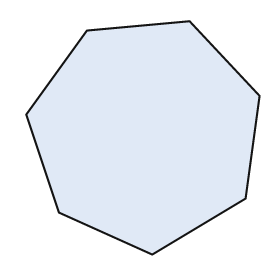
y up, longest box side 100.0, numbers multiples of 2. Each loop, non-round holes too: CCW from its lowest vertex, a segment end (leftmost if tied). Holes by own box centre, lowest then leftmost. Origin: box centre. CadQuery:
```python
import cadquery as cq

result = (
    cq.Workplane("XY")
    .moveTo(4.0, -50.0)
    .lineTo(44.0, -26.0)
    .lineTo(50.0, 18.0)
    .lineTo(20.0, 50.0)
    .lineTo(-24.0, 46.0)
    .lineTo(-50.0, 10.0)
    .lineTo(-36.0, -32.0)
    .close()
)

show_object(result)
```